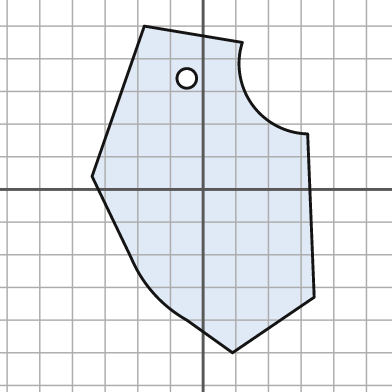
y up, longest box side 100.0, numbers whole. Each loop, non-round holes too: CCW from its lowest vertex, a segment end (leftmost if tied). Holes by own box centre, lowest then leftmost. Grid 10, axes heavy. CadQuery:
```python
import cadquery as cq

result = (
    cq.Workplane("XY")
    .moveTo(9.0, -50.0)
    .lineTo(34.0, -33.0)
    .lineTo(32.0, 17.0)
    .threePointArc((15.0, 26.0), (12.0, 45.0))
    .lineTo(-18.0, 50.0)
    .lineTo(-34.0, 4.0)
    .lineTo(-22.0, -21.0)
    .threePointArc((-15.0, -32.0), (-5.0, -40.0))
    .close()
    .moveTo(-5.0, 34.0)
    .circle(3.0)
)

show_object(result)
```